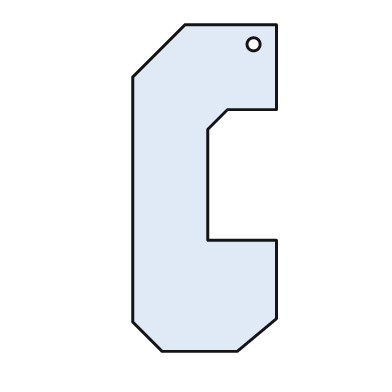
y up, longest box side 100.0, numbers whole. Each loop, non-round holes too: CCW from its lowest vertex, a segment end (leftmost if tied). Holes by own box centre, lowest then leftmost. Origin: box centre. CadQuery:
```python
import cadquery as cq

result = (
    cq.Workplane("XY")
    .moveTo(-13.0, -50.0)
    .lineTo(10.0, -50.0)
    .lineTo(22.0, -40.0)
    .lineTo(22.0, -16.0)
    .lineTo(1.0, -16.0)
    .lineTo(1.0, 18.0)
    .lineTo(7.0, 24.0)
    .lineTo(22.0, 24.0)
    .lineTo(22.0, 50.0)
    .lineTo(-6.0, 50.0)
    .lineTo(-22.0, 34.0)
    .lineTo(-22.0, -41.0)
    .close()
    .moveTo(15.0, 44.0)
    .circle(2.0)
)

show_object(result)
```